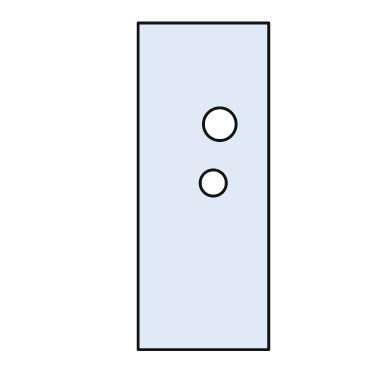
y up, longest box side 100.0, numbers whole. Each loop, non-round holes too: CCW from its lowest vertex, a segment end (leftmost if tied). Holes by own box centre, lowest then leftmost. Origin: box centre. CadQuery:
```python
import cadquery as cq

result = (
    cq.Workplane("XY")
    .moveTo(-20.0, -50.0)
    .lineTo(20.0, -50.0)
    .lineTo(20.0, 50.0)
    .lineTo(-20.0, 50.0)
    .close()
    .moveTo(3.0, 1.0)
    .circle(4.0)
    .moveTo(5.0, 19.0)
    .circle(5.0)
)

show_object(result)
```